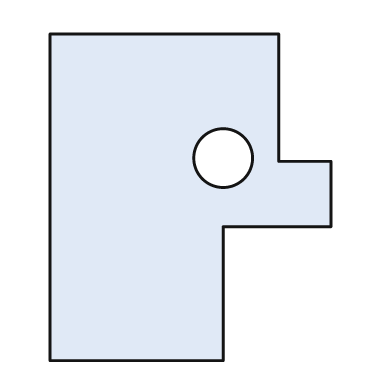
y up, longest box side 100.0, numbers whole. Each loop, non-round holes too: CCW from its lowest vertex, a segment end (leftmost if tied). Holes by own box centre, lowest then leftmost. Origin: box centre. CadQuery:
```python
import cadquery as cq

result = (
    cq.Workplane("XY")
    .moveTo(-43.0, -50.0)
    .lineTo(10.0, -50.0)
    .lineTo(10.0, -9.0)
    .lineTo(43.0, -9.0)
    .lineTo(43.0, 11.0)
    .lineTo(27.0, 11.0)
    .lineTo(27.0, 50.0)
    .lineTo(-43.0, 50.0)
    .close()
    .moveTo(10.0, 12.0)
    .circle(9.0)
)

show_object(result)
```